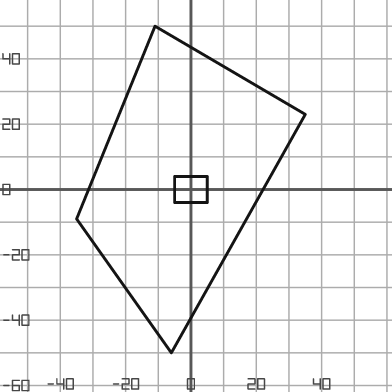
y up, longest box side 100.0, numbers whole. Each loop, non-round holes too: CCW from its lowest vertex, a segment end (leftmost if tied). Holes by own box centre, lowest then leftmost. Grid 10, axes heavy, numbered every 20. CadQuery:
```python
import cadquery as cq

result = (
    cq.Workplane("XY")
    .moveTo(-6.0, -50.0)
    .lineTo(35.0, 23.0)
    .lineTo(-11.0, 50.0)
    .lineTo(-35.0, -9.0)
    .close()
    .moveTo(-5.0, -4.0)
    .lineTo(5.0, -4.0)
    .lineTo(5.0, 4.0)
    .lineTo(-5.0, 4.0)
    .close()
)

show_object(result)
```